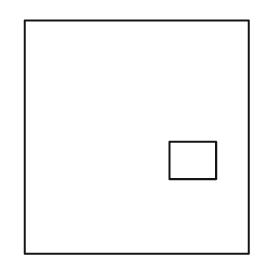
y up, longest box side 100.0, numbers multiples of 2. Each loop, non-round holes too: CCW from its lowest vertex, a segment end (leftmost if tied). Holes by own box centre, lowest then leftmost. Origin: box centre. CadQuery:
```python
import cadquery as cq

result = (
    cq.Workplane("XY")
    .moveTo(-48.0, -50.0)
    .lineTo(48.0, -50.0)
    .lineTo(48.0, 50.0)
    .lineTo(-48.0, 50.0)
    .close()
    .moveTo(14.0, -18.0)
    .lineTo(34.0, -18.0)
    .lineTo(34.0, -2.0)
    .lineTo(14.0, -2.0)
    .close()
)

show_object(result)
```